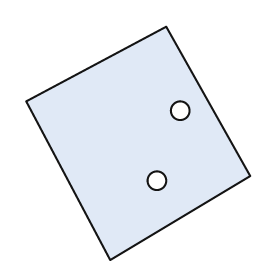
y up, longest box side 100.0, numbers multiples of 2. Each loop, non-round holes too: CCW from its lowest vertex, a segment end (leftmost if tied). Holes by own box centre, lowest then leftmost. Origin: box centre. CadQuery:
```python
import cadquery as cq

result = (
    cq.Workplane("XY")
    .moveTo(-12.0, -50.0)
    .lineTo(48.0, -14.0)
    .lineTo(12.0, 50.0)
    .lineTo(-48.0, 18.0)
    .close()
    .moveTo(8.0, -16.0)
    .circle(4.0)
    .moveTo(18.0, 14.0)
    .circle(4.0)
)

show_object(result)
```